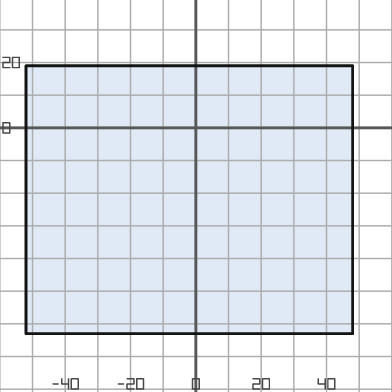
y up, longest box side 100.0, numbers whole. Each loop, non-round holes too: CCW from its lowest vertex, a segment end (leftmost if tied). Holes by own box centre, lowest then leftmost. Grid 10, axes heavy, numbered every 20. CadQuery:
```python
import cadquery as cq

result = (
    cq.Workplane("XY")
    .moveTo(-52.0, -63.0)
    .lineTo(48.0, -63.0)
    .lineTo(48.0, 19.0)
    .lineTo(-52.0, 19.0)
    .close()
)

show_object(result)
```